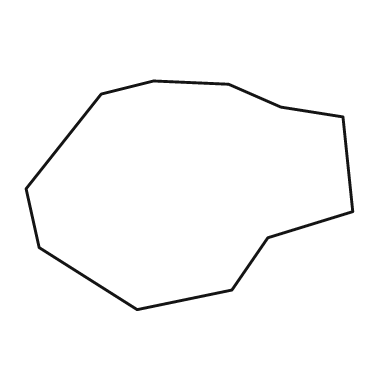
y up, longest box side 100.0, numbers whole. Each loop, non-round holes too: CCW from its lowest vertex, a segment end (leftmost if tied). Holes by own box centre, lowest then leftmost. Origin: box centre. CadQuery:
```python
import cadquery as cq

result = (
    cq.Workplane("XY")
    .moveTo(-16.0, -35.0)
    .lineTo(13.0, -29.0)
    .lineTo(24.0, -13.0)
    .lineTo(50.0, -5.0)
    .lineTo(47.0, 24.0)
    .lineTo(28.0, 27.0)
    .lineTo(12.0, 34.0)
    .lineTo(-11.0, 35.0)
    .lineTo(-27.0, 31.0)
    .lineTo(-50.0, 2.0)
    .lineTo(-46.0, -16.0)
    .close()
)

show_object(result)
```